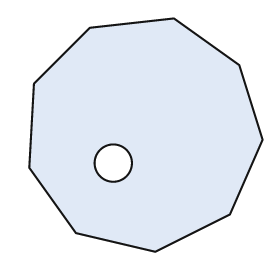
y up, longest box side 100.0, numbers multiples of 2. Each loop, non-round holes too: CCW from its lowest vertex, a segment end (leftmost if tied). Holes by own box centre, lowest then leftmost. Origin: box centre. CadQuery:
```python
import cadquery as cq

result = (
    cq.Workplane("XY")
    .moveTo(4.0, -50.0)
    .lineTo(36.0, -34.0)
    .lineTo(50.0, -2.0)
    .lineTo(40.0, 30.0)
    .lineTo(12.0, 50.0)
    .lineTo(-24.0, 46.0)
    .lineTo(-48.0, 22.0)
    .lineTo(-50.0, -14.0)
    .lineTo(-30.0, -42.0)
    .close()
    .moveTo(-14.0, -12.0)
    .circle(8.0)
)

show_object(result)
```